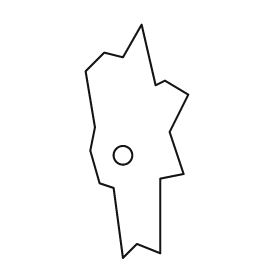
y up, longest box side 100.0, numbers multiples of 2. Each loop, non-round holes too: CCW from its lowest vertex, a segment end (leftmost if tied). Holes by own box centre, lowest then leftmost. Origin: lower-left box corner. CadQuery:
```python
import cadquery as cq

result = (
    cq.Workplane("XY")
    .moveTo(16.0, 0.0)
    .lineTo(22.0, 6.0)
    .lineTo(32.0, 2.0)
    .lineTo(32.0, 34.0)
    .lineTo(42.0, 36.0)
    .lineTo(36.0, 54.0)
    .lineTo(44.0, 70.0)
    .lineTo(34.0, 76.0)
    .lineTo(30.0, 74.0)
    .lineTo(24.0, 100.0)
    .lineTo(16.0, 86.0)
    .lineTo(8.0, 88.0)
    .lineTo(0.0, 80.0)
    .lineTo(4.0, 56.0)
    .lineTo(2.0, 46.0)
    .lineTo(6.0, 32.0)
    .lineTo(12.0, 30.0)
    .close()
    .moveTo(16.0, 44.0)
    .circle(4.0)
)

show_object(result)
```